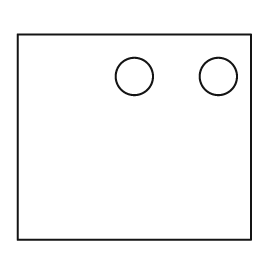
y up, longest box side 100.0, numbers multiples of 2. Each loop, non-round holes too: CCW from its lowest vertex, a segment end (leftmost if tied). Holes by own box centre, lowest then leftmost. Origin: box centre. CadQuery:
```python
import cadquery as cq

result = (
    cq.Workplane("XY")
    .moveTo(-50.0, -44.0)
    .lineTo(50.0, -44.0)
    .lineTo(50.0, 44.0)
    .lineTo(-50.0, 44.0)
    .close()
    .moveTo(0.0, 26.0)
    .circle(8.0)
    .moveTo(36.0, 26.0)
    .circle(8.0)
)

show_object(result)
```